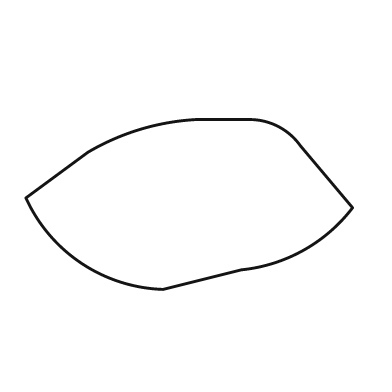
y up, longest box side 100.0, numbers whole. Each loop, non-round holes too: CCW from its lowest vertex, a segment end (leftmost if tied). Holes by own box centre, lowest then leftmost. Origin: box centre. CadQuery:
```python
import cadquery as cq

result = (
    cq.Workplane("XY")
    .moveTo(-8.0, -26.0)
    .lineTo(16.0, -20.0)
    .threePointArc((35.0, -14.0), (50.0, -1.0))
    .lineTo(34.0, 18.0)
    .threePointArc((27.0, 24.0), (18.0, 26.0))
    .lineTo(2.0, 26.0)
    .threePointArc((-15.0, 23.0), (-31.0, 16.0))
    .lineTo(-50.0, 2.0)
    .threePointArc((-33.0, -18.0), (-8.0, -26.0))
    .close()
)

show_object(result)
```